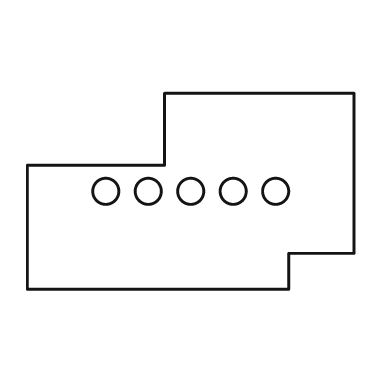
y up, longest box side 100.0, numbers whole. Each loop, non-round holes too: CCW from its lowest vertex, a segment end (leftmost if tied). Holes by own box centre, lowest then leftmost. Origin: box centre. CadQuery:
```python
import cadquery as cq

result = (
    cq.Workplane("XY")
    .moveTo(-50.0, -30.0)
    .lineTo(30.0, -30.0)
    .lineTo(30.0, -19.0)
    .lineTo(50.0, -19.0)
    .lineTo(50.0, 30.0)
    .lineTo(-8.0, 30.0)
    .lineTo(-8.0, 8.0)
    .lineTo(-50.0, 8.0)
    .close()
    .moveTo(-26.0, 0.0)
    .circle(4.0)
    .moveTo(-13.0, 0.0)
    .circle(4.0)
    .moveTo(0.0, 0.0)
    .circle(4.0)
    .moveTo(13.0, 0.0)
    .circle(4.0)
    .moveTo(26.0, 0.0)
    .circle(4.0)
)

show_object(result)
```